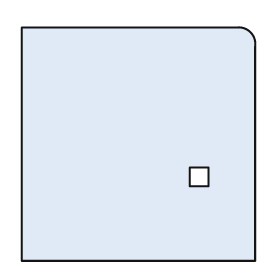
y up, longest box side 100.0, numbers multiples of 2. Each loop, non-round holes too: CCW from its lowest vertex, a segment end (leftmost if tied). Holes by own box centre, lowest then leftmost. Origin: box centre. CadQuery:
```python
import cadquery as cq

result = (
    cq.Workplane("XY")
    .moveTo(-50.0, -50.0)
    .lineTo(50.0, -50.0)
    .lineTo(50.0, 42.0)
    .threePointArc((48.0, 48.0), (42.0, 50.0))
    .lineTo(-50.0, 50.0)
    .close()
    .moveTo(22.0, -18.0)
    .lineTo(30.0, -18.0)
    .lineTo(30.0, -10.0)
    .lineTo(22.0, -10.0)
    .close()
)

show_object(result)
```